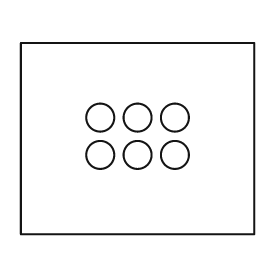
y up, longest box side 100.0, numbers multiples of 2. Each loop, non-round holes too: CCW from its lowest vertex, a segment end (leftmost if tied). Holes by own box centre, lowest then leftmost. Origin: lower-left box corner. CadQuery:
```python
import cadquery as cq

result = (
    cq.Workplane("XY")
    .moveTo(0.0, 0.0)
    .lineTo(100.0, 0.0)
    .lineTo(100.0, 82.0)
    .lineTo(0.0, 82.0)
    .close()
    .moveTo(34.0, 34.0)
    .circle(6.0)
    .moveTo(50.0, 34.0)
    .circle(6.0)
    .moveTo(66.0, 34.0)
    .circle(6.0)
    .moveTo(34.0, 50.0)
    .circle(6.0)
    .moveTo(50.0, 50.0)
    .circle(6.0)
    .moveTo(66.0, 50.0)
    .circle(6.0)
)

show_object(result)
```